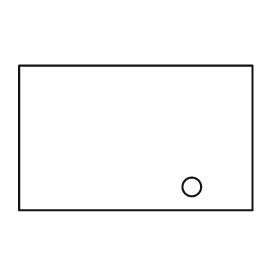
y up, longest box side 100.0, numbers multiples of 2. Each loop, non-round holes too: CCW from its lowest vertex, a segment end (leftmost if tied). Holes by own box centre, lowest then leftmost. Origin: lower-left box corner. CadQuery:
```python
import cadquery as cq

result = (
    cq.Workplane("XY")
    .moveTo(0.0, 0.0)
    .lineTo(100.0, 0.0)
    .lineTo(100.0, 62.0)
    .lineTo(0.0, 62.0)
    .close()
    .moveTo(74.0, 10.0)
    .circle(4.0)
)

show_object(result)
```